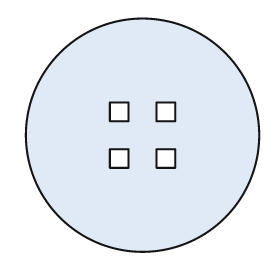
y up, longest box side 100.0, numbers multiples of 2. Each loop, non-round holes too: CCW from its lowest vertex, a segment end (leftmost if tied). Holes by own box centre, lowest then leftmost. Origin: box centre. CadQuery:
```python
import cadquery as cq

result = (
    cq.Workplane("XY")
    .moveTo(0.0, 0.0)
    .circle(50.0)
    .moveTo(-14.0, -14.0)
    .lineTo(-6.0, -14.0)
    .lineTo(-6.0, -6.0)
    .lineTo(-14.0, -6.0)
    .close()
    .moveTo(6.0, -14.0)
    .lineTo(14.0, -14.0)
    .lineTo(14.0, -6.0)
    .lineTo(6.0, -6.0)
    .close()
    .moveTo(-14.0, 6.0)
    .lineTo(-6.0, 6.0)
    .lineTo(-6.0, 14.0)
    .lineTo(-14.0, 14.0)
    .close()
    .moveTo(6.0, 6.0)
    .lineTo(14.0, 6.0)
    .lineTo(14.0, 14.0)
    .lineTo(6.0, 14.0)
    .close()
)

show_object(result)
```